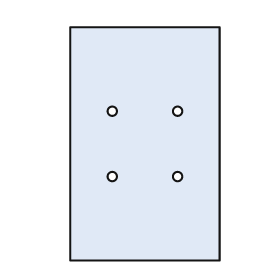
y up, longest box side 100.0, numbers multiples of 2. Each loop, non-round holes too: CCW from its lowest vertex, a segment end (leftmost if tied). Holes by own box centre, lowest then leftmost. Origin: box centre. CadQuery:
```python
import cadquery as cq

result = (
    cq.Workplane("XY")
    .moveTo(-32.0, -50.0)
    .lineTo(32.0, -50.0)
    .lineTo(32.0, 50.0)
    .lineTo(-32.0, 50.0)
    .close()
    .moveTo(-14.0, -14.0)
    .circle(2.0)
    .moveTo(14.0, -14.0)
    .circle(2.0)
    .moveTo(-14.0, 14.0)
    .circle(2.0)
    .moveTo(14.0, 14.0)
    .circle(2.0)
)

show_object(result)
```